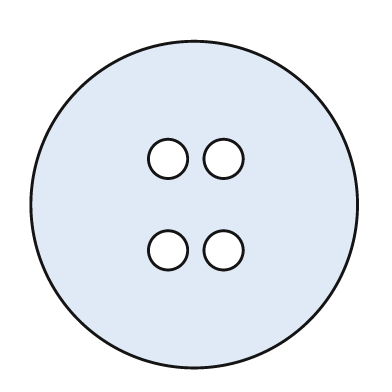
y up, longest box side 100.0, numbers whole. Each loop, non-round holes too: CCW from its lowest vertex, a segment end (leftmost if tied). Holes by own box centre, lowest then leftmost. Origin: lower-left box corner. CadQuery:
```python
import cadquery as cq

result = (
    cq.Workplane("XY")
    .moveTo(50.0, 50.0)
    .circle(50.0)
    .moveTo(42.0, 36.0)
    .circle(6.0)
    .moveTo(59.0, 36.0)
    .circle(6.0)
    .moveTo(42.0, 64.0)
    .circle(6.0)
    .moveTo(59.0, 64.0)
    .circle(6.0)
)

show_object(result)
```